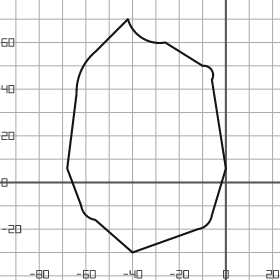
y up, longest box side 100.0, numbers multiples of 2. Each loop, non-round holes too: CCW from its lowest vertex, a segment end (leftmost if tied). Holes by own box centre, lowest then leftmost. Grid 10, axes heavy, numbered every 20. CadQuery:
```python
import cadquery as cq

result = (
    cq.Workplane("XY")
    .moveTo(-40.0, -30.0)
    .lineTo(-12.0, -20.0)
    .threePointArc((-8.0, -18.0), (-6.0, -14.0))
    .lineTo(0.0, 6.0)
    .lineTo(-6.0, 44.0)
    .threePointArc((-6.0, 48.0), (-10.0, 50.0))
    .lineTo(-26.0, 60.0)
    .threePointArc((-36.0, 62.0), (-42.0, 70.0))
    .lineTo(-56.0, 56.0)
    .threePointArc((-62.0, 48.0), (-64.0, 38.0))
    .lineTo(-68.0, 6.0)
    .lineTo(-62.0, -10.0)
    .threePointArc((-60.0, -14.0), (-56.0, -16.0))
    .close()
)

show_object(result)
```